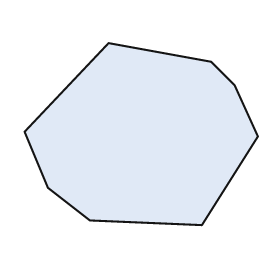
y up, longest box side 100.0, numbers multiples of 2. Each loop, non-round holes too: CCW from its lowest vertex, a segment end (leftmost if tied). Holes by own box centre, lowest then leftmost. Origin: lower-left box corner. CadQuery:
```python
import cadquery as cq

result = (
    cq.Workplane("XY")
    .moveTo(76.0, 0.0)
    .lineTo(100.0, 38.0)
    .lineTo(90.0, 60.0)
    .lineTo(80.0, 70.0)
    .lineTo(36.0, 78.0)
    .lineTo(0.0, 40.0)
    .lineTo(10.0, 16.0)
    .lineTo(28.0, 2.0)
    .close()
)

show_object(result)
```